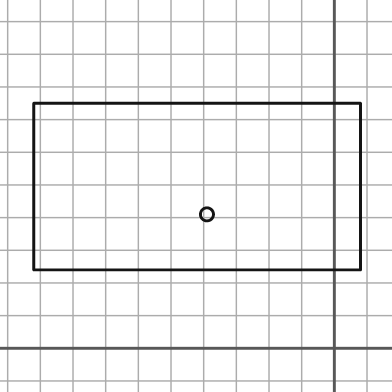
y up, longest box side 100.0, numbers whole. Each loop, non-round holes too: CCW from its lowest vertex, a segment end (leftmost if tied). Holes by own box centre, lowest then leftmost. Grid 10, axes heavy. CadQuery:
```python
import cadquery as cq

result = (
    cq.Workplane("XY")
    .moveTo(-92.0, 24.0)
    .lineTo(8.0, 24.0)
    .lineTo(8.0, 75.0)
    .lineTo(-92.0, 75.0)
    .close()
    .moveTo(-39.0, 41.0)
    .circle(2.0)
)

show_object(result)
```